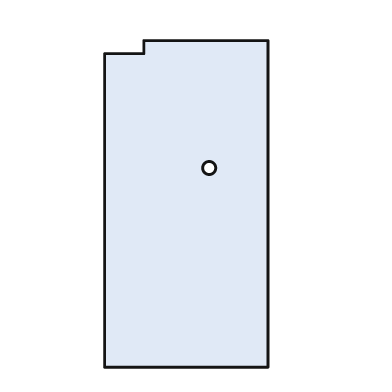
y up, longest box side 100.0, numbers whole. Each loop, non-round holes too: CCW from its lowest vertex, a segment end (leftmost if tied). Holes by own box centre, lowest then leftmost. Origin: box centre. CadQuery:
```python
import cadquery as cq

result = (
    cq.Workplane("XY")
    .moveTo(-25.0, -50.0)
    .lineTo(25.0, -50.0)
    .lineTo(25.0, 50.0)
    .lineTo(-13.0, 50.0)
    .lineTo(-13.0, 46.0)
    .lineTo(-25.0, 46.0)
    .close()
    .moveTo(7.0, 11.0)
    .circle(2.0)
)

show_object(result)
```